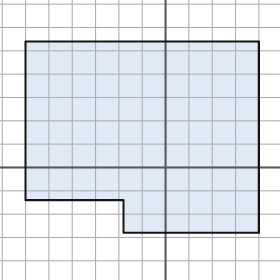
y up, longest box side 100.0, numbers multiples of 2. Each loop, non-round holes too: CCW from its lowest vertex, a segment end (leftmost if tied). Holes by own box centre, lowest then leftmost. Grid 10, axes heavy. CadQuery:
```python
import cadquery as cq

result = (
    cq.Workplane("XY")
    .moveTo(-18.0, -28.0)
    .lineTo(40.0, -28.0)
    .lineTo(40.0, 54.0)
    .lineTo(-60.0, 54.0)
    .lineTo(-60.0, -14.0)
    .lineTo(-18.0, -14.0)
    .close()
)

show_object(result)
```